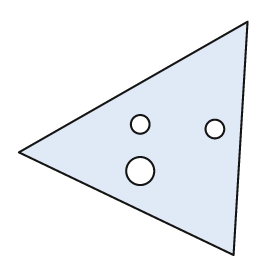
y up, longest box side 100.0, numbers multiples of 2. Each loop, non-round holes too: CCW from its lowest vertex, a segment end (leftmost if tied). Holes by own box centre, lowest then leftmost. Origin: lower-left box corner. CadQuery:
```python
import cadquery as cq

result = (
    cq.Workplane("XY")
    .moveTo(92.0, 0.0)
    .lineTo(98.0, 100.0)
    .lineTo(0.0, 44.0)
    .close()
    .moveTo(52.0, 36.0)
    .circle(6.0)
    .moveTo(84.0, 54.0)
    .circle(4.0)
    .moveTo(52.0, 56.0)
    .circle(4.0)
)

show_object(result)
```